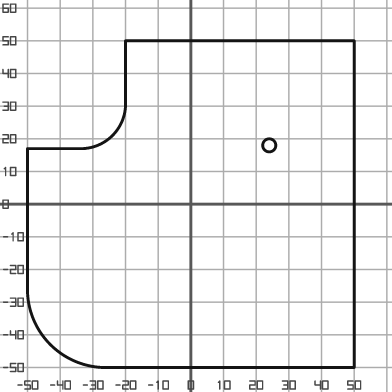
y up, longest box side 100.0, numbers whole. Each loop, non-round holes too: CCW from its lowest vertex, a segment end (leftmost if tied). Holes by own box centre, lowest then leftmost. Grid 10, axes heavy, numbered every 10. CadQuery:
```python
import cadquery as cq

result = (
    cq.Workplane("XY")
    .moveTo(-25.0, -50.0)
    .lineTo(50.0, -50.0)
    .lineTo(50.0, 50.0)
    .lineTo(-20.0, 50.0)
    .lineTo(-20.0, 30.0)
    .threePointArc((-24.0, 21.0), (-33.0, 17.0))
    .lineTo(-50.0, 17.0)
    .lineTo(-50.0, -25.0)
    .threePointArc((-43.0, -43.0), (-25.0, -50.0))
    .close()
    .moveTo(24.0, 18.0)
    .circle(2.0)
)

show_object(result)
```